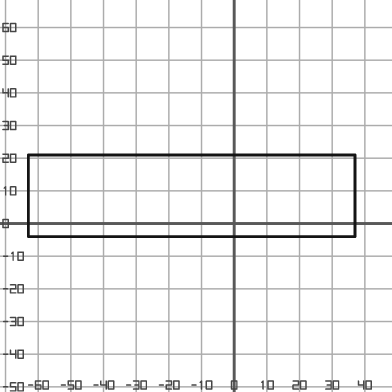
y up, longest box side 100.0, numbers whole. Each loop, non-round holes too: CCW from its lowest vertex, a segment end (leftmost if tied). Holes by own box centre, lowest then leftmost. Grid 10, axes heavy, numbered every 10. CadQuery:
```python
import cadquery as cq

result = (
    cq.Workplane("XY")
    .moveTo(-63.0, -4.0)
    .lineTo(37.0, -4.0)
    .lineTo(37.0, 21.0)
    .lineTo(-63.0, 21.0)
    .close()
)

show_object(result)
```